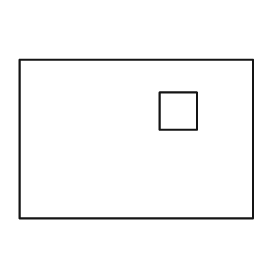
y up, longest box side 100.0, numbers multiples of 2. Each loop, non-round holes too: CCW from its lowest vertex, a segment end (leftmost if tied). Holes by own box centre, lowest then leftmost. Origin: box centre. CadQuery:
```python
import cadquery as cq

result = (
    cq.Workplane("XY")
    .moveTo(-50.0, -34.0)
    .lineTo(50.0, -34.0)
    .lineTo(50.0, 34.0)
    .lineTo(-50.0, 34.0)
    .close()
    .moveTo(10.0, 4.0)
    .lineTo(26.0, 4.0)
    .lineTo(26.0, 20.0)
    .lineTo(10.0, 20.0)
    .close()
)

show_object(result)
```